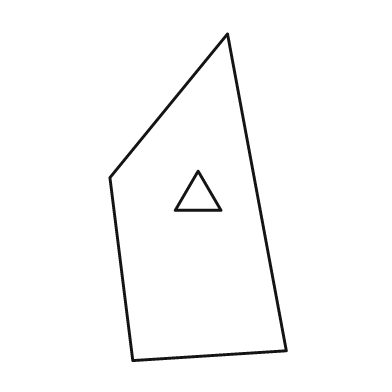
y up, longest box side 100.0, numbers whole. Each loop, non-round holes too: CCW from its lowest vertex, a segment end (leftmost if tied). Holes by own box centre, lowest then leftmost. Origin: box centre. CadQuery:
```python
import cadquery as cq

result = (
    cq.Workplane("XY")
    .moveTo(-20.0, -50.0)
    .lineTo(27.0, -47.0)
    .lineTo(9.0, 50.0)
    .lineTo(-27.0, 6.0)
    .close()
    .moveTo(-7.0, -4.0)
    .lineTo(7.0, -4.0)
    .lineTo(0.0, 8.0)
    .close()
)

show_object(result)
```